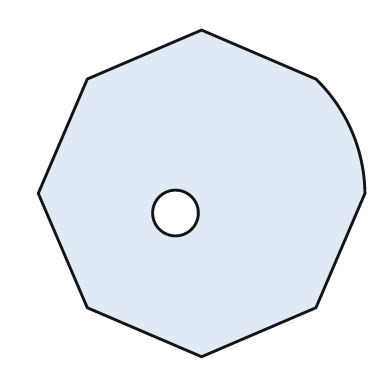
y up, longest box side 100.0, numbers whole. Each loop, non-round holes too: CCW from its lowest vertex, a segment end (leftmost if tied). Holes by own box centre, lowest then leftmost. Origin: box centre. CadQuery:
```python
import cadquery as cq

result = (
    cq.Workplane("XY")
    .moveTo(0.0, -50.0)
    .lineTo(35.0, -35.0)
    .lineTo(50.0, 0.0)
    .threePointArc((46.0, 19.0), (35.0, 35.0))
    .lineTo(0.0, 50.0)
    .lineTo(-35.0, 35.0)
    .lineTo(-50.0, 0.0)
    .lineTo(-35.0, -35.0)
    .close()
    .moveTo(-8.0, -6.0)
    .circle(7.0)
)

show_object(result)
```